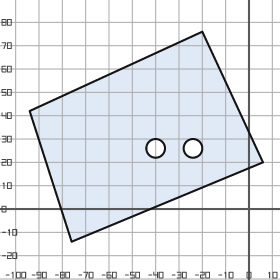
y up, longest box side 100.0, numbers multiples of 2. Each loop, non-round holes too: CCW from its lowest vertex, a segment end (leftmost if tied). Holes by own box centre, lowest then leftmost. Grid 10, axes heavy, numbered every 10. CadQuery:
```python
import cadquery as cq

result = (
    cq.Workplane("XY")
    .moveTo(-76.0, -14.0)
    .lineTo(6.0, 20.0)
    .lineTo(-20.0, 76.0)
    .lineTo(-94.0, 42.0)
    .close()
    .moveTo(-40.0, 26.0)
    .circle(4.0)
    .moveTo(-24.0, 26.0)
    .circle(4.0)
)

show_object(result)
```